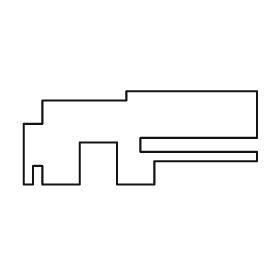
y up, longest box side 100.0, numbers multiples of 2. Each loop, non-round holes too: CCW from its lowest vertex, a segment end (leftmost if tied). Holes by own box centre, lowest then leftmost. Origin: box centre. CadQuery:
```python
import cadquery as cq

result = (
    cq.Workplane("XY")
    .moveTo(-50.0, -20.0)
    .lineTo(-46.0, -20.0)
    .lineTo(-46.0, -12.0)
    .lineTo(-42.0, -12.0)
    .lineTo(-42.0, -20.0)
    .lineTo(-26.0, -20.0)
    .lineTo(-26.0, -2.0)
    .lineTo(-10.0, -2.0)
    .lineTo(-10.0, -20.0)
    .lineTo(6.0, -20.0)
    .lineTo(6.0, -10.0)
    .lineTo(50.0, -10.0)
    .lineTo(50.0, -6.0)
    .lineTo(0.0, -6.0)
    .lineTo(0.0, 0.0)
    .lineTo(50.0, 0.0)
    .lineTo(50.0, 20.0)
    .lineTo(-6.0, 20.0)
    .lineTo(-6.0, 16.0)
    .lineTo(-42.0, 16.0)
    .lineTo(-42.0, 6.0)
    .lineTo(-50.0, 6.0)
    .close()
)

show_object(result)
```